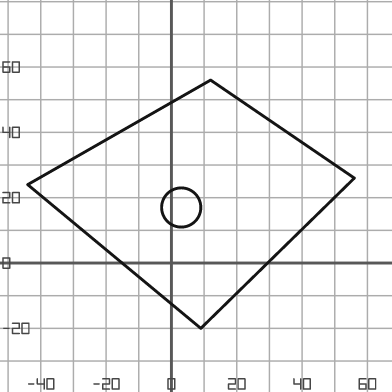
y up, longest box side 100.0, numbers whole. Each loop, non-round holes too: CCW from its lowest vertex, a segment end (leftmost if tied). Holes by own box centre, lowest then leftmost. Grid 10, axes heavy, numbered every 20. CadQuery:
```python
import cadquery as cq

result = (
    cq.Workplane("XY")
    .moveTo(9.0, -20.0)
    .lineTo(56.0, 26.0)
    .lineTo(12.0, 56.0)
    .lineTo(-44.0, 24.0)
    .close()
    .moveTo(3.0, 17.0)
    .circle(6.0)
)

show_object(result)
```